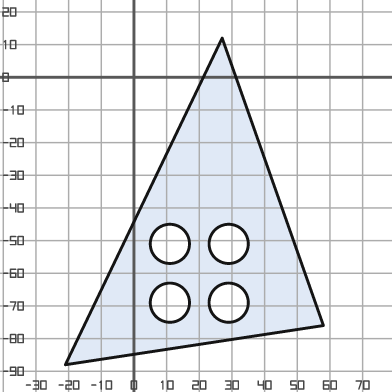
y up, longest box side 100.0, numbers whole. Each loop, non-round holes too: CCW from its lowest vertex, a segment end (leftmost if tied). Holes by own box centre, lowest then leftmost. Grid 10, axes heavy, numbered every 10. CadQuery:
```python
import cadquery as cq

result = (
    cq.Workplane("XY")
    .moveTo(-21.0, -88.0)
    .lineTo(58.0, -76.0)
    .lineTo(27.0, 12.0)
    .close()
    .moveTo(11.0, -69.0)
    .circle(6.0)
    .moveTo(29.0, -69.0)
    .circle(6.0)
    .moveTo(11.0, -51.0)
    .circle(6.0)
    .moveTo(29.0, -51.0)
    .circle(6.0)
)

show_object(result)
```